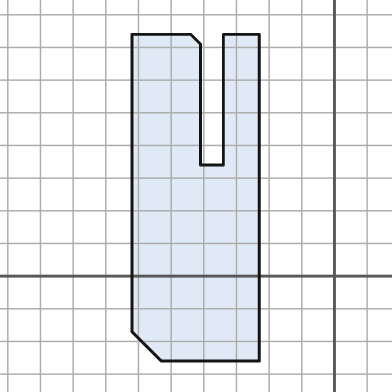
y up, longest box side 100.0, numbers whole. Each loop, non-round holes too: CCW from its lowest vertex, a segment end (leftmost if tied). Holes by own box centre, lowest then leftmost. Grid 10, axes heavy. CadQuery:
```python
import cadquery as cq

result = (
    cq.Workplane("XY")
    .moveTo(-53.0, -26.0)
    .lineTo(-23.0, -26.0)
    .lineTo(-23.0, 74.0)
    .lineTo(-34.0, 74.0)
    .lineTo(-34.0, 34.0)
    .lineTo(-41.0, 34.0)
    .lineTo(-41.0, 71.0)
    .lineTo(-44.0, 74.0)
    .lineTo(-62.0, 74.0)
    .lineTo(-62.0, -17.0)
    .close()
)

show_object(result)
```